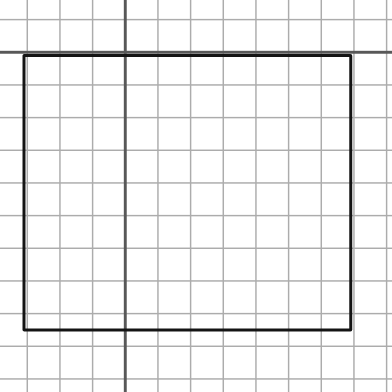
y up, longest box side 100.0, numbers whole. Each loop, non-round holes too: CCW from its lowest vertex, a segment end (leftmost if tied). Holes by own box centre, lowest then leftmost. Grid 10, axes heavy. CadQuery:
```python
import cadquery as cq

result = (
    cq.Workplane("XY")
    .moveTo(-31.0, -85.0)
    .lineTo(69.0, -85.0)
    .lineTo(69.0, -1.0)
    .lineTo(-31.0, -1.0)
    .close()
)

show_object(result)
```